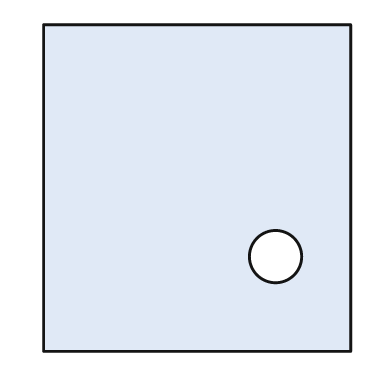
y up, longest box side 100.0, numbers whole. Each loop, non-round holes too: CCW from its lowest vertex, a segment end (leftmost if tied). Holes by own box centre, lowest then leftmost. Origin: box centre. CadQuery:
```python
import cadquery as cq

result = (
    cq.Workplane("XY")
    .moveTo(-47.0, -50.0)
    .lineTo(47.0, -50.0)
    .lineTo(47.0, 50.0)
    .lineTo(-47.0, 50.0)
    .close()
    .moveTo(24.0, -21.0)
    .circle(8.0)
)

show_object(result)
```